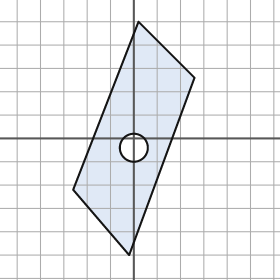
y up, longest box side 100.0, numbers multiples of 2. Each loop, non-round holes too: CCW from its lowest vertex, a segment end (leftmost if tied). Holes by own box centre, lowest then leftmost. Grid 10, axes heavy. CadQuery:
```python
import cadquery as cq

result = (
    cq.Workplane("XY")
    .moveTo(-2.0, -50.0)
    .lineTo(26.0, 26.0)
    .lineTo(2.0, 50.0)
    .lineTo(-26.0, -22.0)
    .close()
    .moveTo(0.0, -4.0)
    .circle(6.0)
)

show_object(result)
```